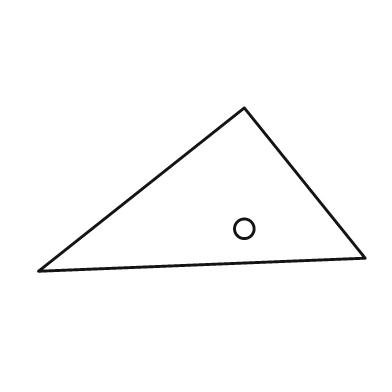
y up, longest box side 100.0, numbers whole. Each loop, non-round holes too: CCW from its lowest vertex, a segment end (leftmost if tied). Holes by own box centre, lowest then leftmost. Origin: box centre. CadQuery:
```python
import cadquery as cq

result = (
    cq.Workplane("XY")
    .moveTo(-50.0, -25.0)
    .lineTo(50.0, -21.0)
    .lineTo(13.0, 25.0)
    .close()
    .moveTo(13.0, -12.0)
    .circle(3.0)
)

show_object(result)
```